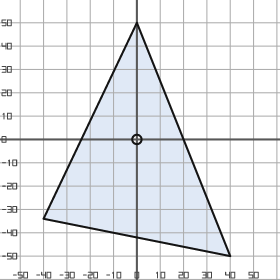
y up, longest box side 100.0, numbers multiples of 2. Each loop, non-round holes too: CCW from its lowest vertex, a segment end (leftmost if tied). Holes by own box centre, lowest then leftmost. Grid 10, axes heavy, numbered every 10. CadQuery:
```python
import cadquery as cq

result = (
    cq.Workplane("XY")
    .moveTo(40.0, -50.0)
    .lineTo(0.0, 50.0)
    .lineTo(-40.0, -34.0)
    .close()
    .moveTo(0.0, 0.0)
    .circle(2.0)
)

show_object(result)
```